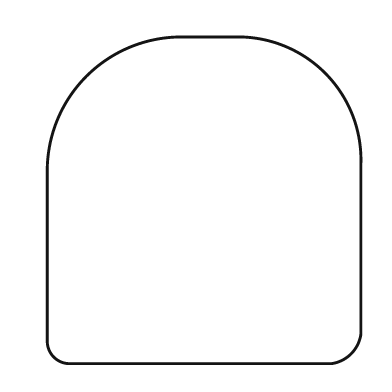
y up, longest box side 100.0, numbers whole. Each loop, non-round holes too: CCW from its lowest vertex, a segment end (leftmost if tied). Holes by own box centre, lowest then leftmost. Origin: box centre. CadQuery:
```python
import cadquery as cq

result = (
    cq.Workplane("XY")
    .moveTo(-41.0, -50.0)
    .lineTo(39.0, -50.0)
    .threePointArc((45.0, -47.0), (48.0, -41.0))
    .lineTo(48.0, 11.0)
    .threePointArc((37.0, 39.0), (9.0, 50.0))
    .lineTo(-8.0, 50.0)
    .threePointArc((-36.0, 38.0), (-48.0, 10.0))
    .lineTo(-48.0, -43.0)
    .threePointArc((-46.0, -48.0), (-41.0, -50.0))
    .close()
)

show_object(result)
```